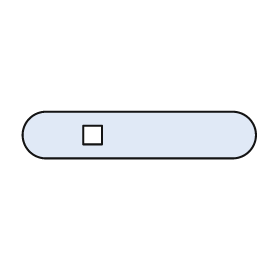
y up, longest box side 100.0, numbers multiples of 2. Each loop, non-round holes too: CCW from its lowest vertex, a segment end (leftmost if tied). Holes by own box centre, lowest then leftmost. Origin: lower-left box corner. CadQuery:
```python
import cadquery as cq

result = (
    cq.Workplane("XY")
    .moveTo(10.0, 0.0)
    .lineTo(90.0, 0.0)
    .threePointArc((100.0, 10.0), (90.0, 20.0))
    .lineTo(10.0, 20.0)
    .threePointArc((0.0, 10.0), (10.0, 0.0))
    .close()
    .moveTo(26.0, 6.0)
    .lineTo(34.0, 6.0)
    .lineTo(34.0, 14.0)
    .lineTo(26.0, 14.0)
    .close()
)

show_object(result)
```